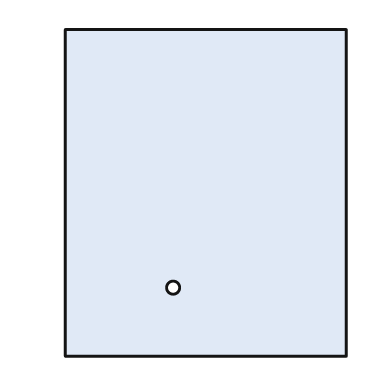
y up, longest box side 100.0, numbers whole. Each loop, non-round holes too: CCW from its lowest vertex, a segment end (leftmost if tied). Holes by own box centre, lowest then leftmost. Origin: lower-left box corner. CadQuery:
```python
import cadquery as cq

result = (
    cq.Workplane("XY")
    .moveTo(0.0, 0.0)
    .lineTo(86.0, 0.0)
    .lineTo(86.0, 100.0)
    .lineTo(0.0, 100.0)
    .close()
    .moveTo(33.0, 21.0)
    .circle(2.0)
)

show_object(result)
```